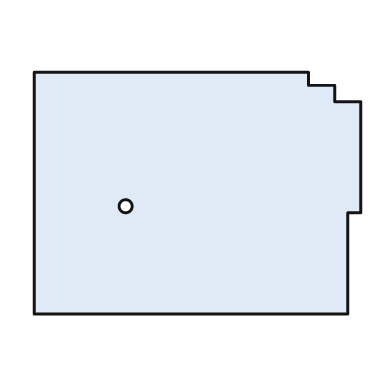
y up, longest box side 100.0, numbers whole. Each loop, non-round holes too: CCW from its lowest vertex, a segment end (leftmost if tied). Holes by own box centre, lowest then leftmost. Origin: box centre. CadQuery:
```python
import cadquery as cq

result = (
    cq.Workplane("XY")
    .moveTo(-50.0, -37.0)
    .lineTo(46.0, -37.0)
    .lineTo(46.0, -6.0)
    .lineTo(50.0, -6.0)
    .lineTo(50.0, 28.0)
    .lineTo(42.0, 28.0)
    .lineTo(42.0, 33.0)
    .lineTo(34.0, 33.0)
    .lineTo(34.0, 37.0)
    .lineTo(-50.0, 37.0)
    .close()
    .moveTo(-22.0, -4.0)
    .circle(2.0)
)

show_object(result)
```